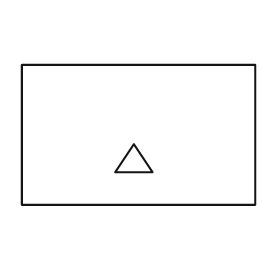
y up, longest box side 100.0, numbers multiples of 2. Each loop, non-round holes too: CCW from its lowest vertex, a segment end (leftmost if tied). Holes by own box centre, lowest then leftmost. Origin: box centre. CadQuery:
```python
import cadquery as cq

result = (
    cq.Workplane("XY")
    .moveTo(-50.0, -30.0)
    .lineTo(50.0, -30.0)
    .lineTo(50.0, 30.0)
    .lineTo(-50.0, 30.0)
    .close()
    .moveTo(-10.0, -16.0)
    .lineTo(6.0, -16.0)
    .lineTo(-2.0, -4.0)
    .close()
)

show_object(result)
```